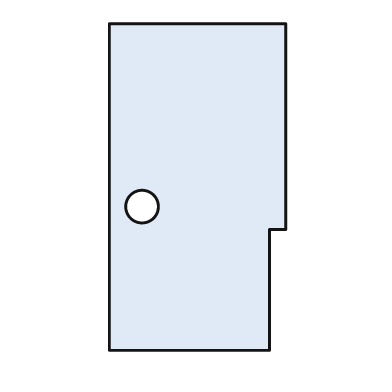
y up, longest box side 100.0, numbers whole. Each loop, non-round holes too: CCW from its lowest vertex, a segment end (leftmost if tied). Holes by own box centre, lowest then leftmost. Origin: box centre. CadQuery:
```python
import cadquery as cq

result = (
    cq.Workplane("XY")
    .moveTo(-27.0, -50.0)
    .lineTo(22.0, -50.0)
    .lineTo(22.0, -13.0)
    .lineTo(27.0, -13.0)
    .lineTo(27.0, 50.0)
    .lineTo(-27.0, 50.0)
    .close()
    .moveTo(-17.0, -6.0)
    .circle(5.0)
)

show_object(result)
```